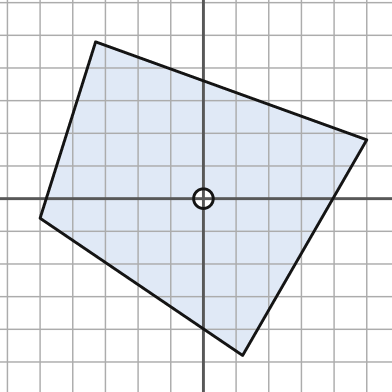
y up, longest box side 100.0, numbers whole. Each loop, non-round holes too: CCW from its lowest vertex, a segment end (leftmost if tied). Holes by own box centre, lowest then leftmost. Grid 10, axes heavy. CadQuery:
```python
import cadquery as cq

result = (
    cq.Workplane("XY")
    .moveTo(12.0, -48.0)
    .lineTo(50.0, 18.0)
    .lineTo(-33.0, 48.0)
    .lineTo(-50.0, -6.0)
    .close()
    .moveTo(0.0, 0.0)
    .circle(3.0)
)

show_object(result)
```